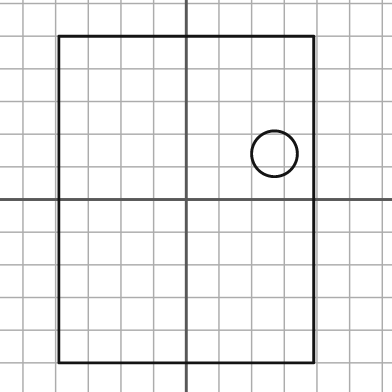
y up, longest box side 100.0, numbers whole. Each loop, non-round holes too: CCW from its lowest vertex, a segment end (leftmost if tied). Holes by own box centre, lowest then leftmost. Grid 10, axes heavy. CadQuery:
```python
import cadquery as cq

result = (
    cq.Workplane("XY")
    .moveTo(-39.0, -50.0)
    .lineTo(39.0, -50.0)
    .lineTo(39.0, 50.0)
    .lineTo(-39.0, 50.0)
    .close()
    .moveTo(27.0, 14.0)
    .circle(7.0)
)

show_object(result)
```